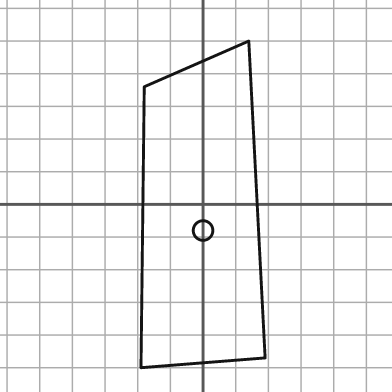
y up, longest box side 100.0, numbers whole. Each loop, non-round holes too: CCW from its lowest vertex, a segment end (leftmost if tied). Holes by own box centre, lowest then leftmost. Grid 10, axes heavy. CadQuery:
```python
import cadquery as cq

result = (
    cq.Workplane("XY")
    .moveTo(-19.0, -50.0)
    .lineTo(19.0, -47.0)
    .lineTo(14.0, 50.0)
    .lineTo(-18.0, 36.0)
    .close()
    .moveTo(0.0, -8.0)
    .circle(3.0)
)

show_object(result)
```